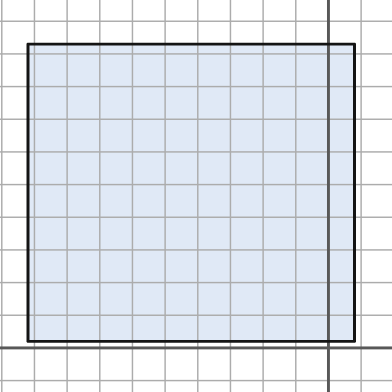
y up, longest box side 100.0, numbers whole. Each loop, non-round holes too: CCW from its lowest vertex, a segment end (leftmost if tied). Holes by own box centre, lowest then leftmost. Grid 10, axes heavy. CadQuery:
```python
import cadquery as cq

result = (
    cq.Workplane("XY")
    .moveTo(-92.0, 2.0)
    .lineTo(8.0, 2.0)
    .lineTo(8.0, 93.0)
    .lineTo(-92.0, 93.0)
    .close()
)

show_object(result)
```